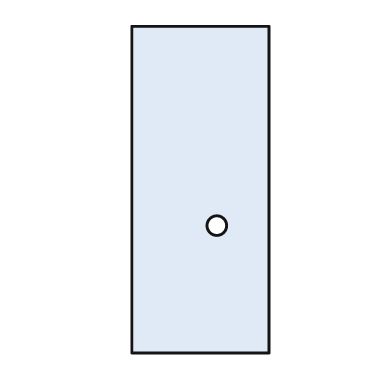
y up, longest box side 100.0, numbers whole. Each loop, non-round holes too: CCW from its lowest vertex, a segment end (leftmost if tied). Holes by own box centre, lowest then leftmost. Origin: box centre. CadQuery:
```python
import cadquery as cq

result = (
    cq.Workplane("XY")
    .moveTo(-21.0, -50.0)
    .lineTo(21.0, -50.0)
    .lineTo(21.0, 50.0)
    .lineTo(-21.0, 50.0)
    .close()
    .moveTo(5.0, -11.0)
    .circle(3.0)
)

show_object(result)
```